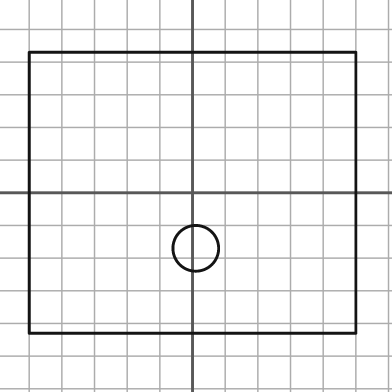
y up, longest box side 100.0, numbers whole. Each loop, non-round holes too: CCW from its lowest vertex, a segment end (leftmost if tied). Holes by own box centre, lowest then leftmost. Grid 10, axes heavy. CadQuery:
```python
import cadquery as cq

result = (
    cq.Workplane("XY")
    .moveTo(-50.0, -43.0)
    .lineTo(50.0, -43.0)
    .lineTo(50.0, 43.0)
    .lineTo(-50.0, 43.0)
    .close()
    .moveTo(1.0, -17.0)
    .circle(7.0)
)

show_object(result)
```